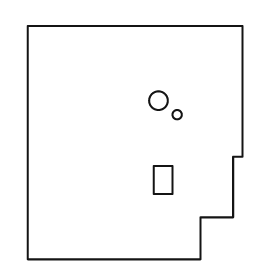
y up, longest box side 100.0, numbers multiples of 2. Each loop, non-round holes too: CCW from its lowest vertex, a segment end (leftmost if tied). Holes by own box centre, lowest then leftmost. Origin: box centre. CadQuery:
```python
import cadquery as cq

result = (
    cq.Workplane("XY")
    .moveTo(-46.0, -50.0)
    .lineTo(28.0, -50.0)
    .lineTo(28.0, -32.0)
    .lineTo(42.0, -32.0)
    .lineTo(42.0, -6.0)
    .lineTo(46.0, -6.0)
    .lineTo(46.0, 50.0)
    .lineTo(-46.0, 50.0)
    .close()
    .moveTo(8.0, -22.0)
    .lineTo(16.0, -22.0)
    .lineTo(16.0, -10.0)
    .lineTo(8.0, -10.0)
    .close()
    .moveTo(18.0, 12.0)
    .circle(2.0)
    .moveTo(10.0, 18.0)
    .circle(4.0)
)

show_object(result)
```